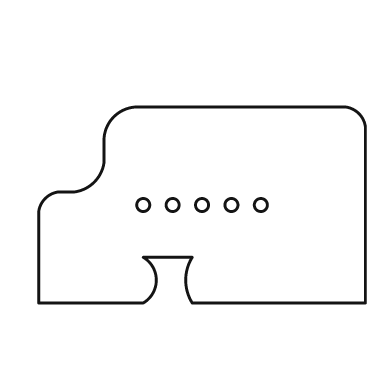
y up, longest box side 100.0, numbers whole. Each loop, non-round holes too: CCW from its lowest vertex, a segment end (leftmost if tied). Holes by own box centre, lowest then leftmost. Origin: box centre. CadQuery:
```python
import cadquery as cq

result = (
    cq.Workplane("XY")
    .moveTo(-50.0, -30.0)
    .lineTo(-18.0, -30.0)
    .threePointArc((-14.0, -23.0), (-18.0, -16.0))
    .lineTo(-3.0, -16.0)
    .threePointArc((-5.0, -23.0), (-3.0, -30.0))
    .lineTo(50.0, -30.0)
    .lineTo(50.0, 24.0)
    .threePointArc((48.0, 28.0), (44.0, 30.0))
    .lineTo(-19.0, 30.0)
    .threePointArc((-27.0, 27.0), (-30.0, 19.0))
    .lineTo(-30.0, 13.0)
    .threePointArc((-33.0, 7.0), (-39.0, 4.0))
    .lineTo(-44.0, 4.0)
    .threePointArc((-48.0, 2.0), (-50.0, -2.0))
    .close()
    .moveTo(-18.0, 0.0)
    .circle(2.0)
    .moveTo(-9.0, 0.0)
    .circle(2.0)
    .moveTo(0.0, 0.0)
    .circle(2.0)
    .moveTo(9.0, 0.0)
    .circle(2.0)
    .moveTo(18.0, 0.0)
    .circle(2.0)
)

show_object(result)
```